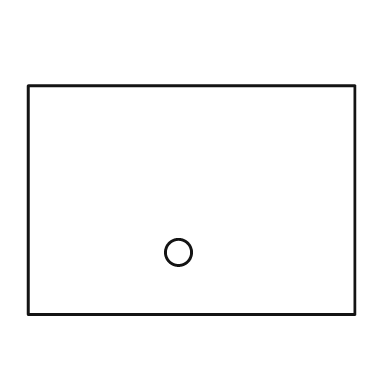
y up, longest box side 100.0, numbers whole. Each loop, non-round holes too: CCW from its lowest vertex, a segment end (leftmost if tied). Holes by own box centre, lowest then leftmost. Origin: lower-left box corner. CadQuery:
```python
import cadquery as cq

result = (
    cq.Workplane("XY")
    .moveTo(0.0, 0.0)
    .lineTo(100.0, 0.0)
    .lineTo(100.0, 70.0)
    .lineTo(0.0, 70.0)
    .close()
    .moveTo(46.0, 19.0)
    .circle(4.0)
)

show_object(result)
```